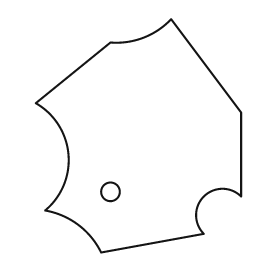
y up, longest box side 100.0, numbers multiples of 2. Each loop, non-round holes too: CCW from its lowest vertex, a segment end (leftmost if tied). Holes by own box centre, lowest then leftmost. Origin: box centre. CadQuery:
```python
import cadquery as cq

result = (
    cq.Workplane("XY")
    .moveTo(-16.0, -50.0)
    .lineTo(28.0, -42.0)
    .threePointArc((28.0, -26.0), (44.0, -26.0))
    .lineTo(44.0, 10.0)
    .lineTo(14.0, 50.0)
    .threePointArc((2.0, 42.0), (-12.0, 40.0))
    .lineTo(-44.0, 14.0)
    .threePointArc((-30.0, -8.0), (-40.0, -32.0))
    .threePointArc((-26.0, -38.0), (-16.0, -50.0))
    .close()
    .moveTo(-12.0, -24.0)
    .circle(4.0)
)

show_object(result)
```